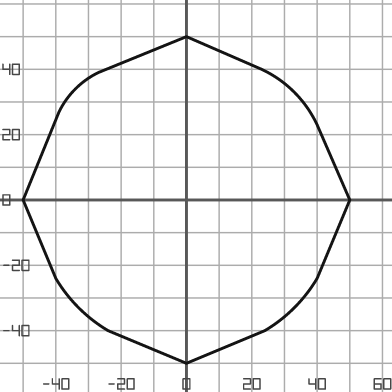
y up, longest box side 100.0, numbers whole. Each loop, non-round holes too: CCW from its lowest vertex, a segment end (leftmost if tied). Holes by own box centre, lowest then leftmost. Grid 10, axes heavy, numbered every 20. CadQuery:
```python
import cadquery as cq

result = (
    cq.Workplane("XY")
    .moveTo(0.0, -50.0)
    .lineTo(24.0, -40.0)
    .threePointArc((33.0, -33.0), (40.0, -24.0))
    .lineTo(50.0, 0.0)
    .lineTo(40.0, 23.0)
    .threePointArc((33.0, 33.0), (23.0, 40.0))
    .lineTo(0.0, 50.0)
    .lineTo(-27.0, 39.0)
    .threePointArc((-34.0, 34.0), (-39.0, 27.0))
    .lineTo(-50.0, 0.0)
    .lineTo(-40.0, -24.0)
    .threePointArc((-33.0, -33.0), (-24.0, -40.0))
    .close()
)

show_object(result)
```